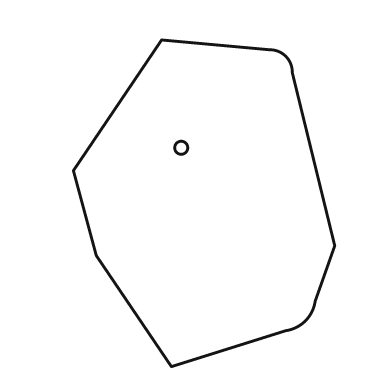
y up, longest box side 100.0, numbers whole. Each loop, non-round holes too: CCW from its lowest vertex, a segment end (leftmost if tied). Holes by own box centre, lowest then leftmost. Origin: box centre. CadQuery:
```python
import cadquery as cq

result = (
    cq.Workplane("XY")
    .moveTo(-10.0, -50.0)
    .lineTo(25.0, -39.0)
    .threePointArc((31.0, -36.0), (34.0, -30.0))
    .lineTo(40.0, -13.0)
    .lineTo(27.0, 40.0)
    .threePointArc((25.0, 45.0), (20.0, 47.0))
    .lineTo(-13.0, 50.0)
    .lineTo(-40.0, 10.0)
    .lineTo(-33.0, -16.0)
    .close()
    .moveTo(-7.0, 17.0)
    .circle(2.0)
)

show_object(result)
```